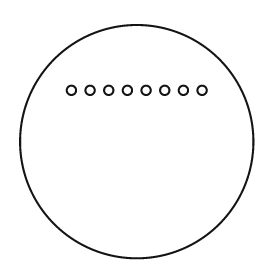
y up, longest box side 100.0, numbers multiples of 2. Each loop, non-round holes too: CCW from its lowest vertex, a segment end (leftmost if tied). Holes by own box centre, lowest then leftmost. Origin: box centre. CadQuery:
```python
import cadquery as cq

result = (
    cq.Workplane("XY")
    .moveTo(0.0, 0.0)
    .circle(50.0)
    .moveTo(-28.0, 22.0)
    .circle(2.0)
    .moveTo(-20.0, 22.0)
    .circle(2.0)
    .moveTo(-12.0, 22.0)
    .circle(2.0)
    .moveTo(-4.0, 22.0)
    .circle(2.0)
    .moveTo(4.0, 22.0)
    .circle(2.0)
    .moveTo(12.0, 22.0)
    .circle(2.0)
    .moveTo(20.0, 22.0)
    .circle(2.0)
    .moveTo(28.0, 22.0)
    .circle(2.0)
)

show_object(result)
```